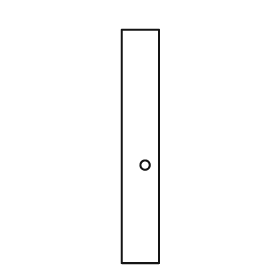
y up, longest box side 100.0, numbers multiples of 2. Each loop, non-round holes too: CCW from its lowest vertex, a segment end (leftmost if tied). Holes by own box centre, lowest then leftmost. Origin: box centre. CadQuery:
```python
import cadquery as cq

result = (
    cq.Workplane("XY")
    .moveTo(-8.0, -50.0)
    .lineTo(8.0, -50.0)
    .lineTo(8.0, 50.0)
    .lineTo(-8.0, 50.0)
    .close()
    .moveTo(2.0, -8.0)
    .circle(2.0)
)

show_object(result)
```